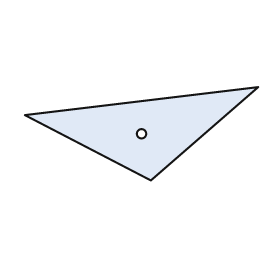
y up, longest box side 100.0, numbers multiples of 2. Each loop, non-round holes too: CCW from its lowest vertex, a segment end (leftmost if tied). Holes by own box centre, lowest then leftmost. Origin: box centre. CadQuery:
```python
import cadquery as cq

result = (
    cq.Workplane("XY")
    .moveTo(4.0, -20.0)
    .lineTo(50.0, 20.0)
    .lineTo(-50.0, 8.0)
    .close()
    .moveTo(0.0, 0.0)
    .circle(2.0)
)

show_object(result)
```